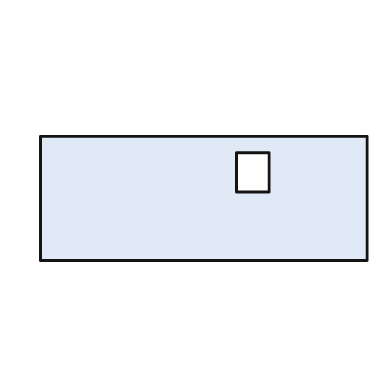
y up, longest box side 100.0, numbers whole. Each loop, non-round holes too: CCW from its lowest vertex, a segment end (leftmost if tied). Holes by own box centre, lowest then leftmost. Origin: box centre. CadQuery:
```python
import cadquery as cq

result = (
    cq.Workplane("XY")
    .moveTo(-50.0, -19.0)
    .lineTo(50.0, -19.0)
    .lineTo(50.0, 19.0)
    .lineTo(-50.0, 19.0)
    .close()
    .moveTo(10.0, 2.0)
    .lineTo(20.0, 2.0)
    .lineTo(20.0, 14.0)
    .lineTo(10.0, 14.0)
    .close()
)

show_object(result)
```